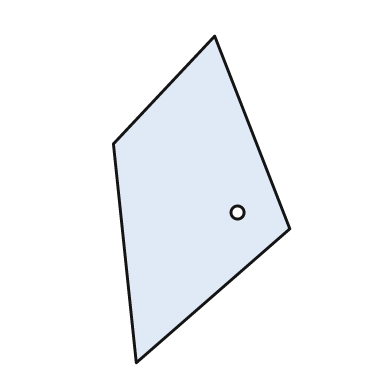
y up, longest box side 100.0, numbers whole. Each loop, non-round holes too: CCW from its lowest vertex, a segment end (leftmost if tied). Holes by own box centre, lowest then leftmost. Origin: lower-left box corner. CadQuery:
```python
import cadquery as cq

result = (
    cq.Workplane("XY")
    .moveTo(7.0, 0.0)
    .lineTo(54.0, 41.0)
    .lineTo(31.0, 100.0)
    .lineTo(0.0, 67.0)
    .close()
    .moveTo(38.0, 46.0)
    .circle(2.0)
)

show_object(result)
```